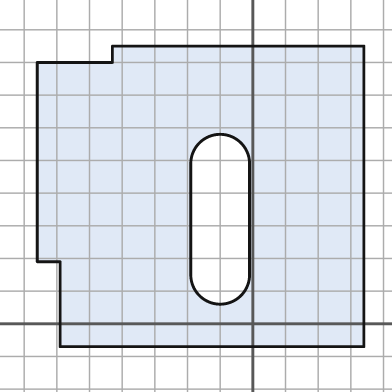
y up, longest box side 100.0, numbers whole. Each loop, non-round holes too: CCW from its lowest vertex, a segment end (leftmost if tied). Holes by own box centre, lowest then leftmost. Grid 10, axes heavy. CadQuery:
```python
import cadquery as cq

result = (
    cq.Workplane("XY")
    .moveTo(-59.0, -7.0)
    .lineTo(34.0, -7.0)
    .lineTo(34.0, 85.0)
    .lineTo(-43.0, 85.0)
    .lineTo(-43.0, 80.0)
    .lineTo(-66.0, 80.0)
    .lineTo(-66.0, 19.0)
    .lineTo(-59.0, 19.0)
    .close()
    .moveTo(-19.0, 15.0)
    .threePointArc((-10.0, 6.0), (-1.0, 15.0))
    .lineTo(-1.0, 49.0)
    .threePointArc((-10.0, 58.0), (-19.0, 49.0))
    .close()
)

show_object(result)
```